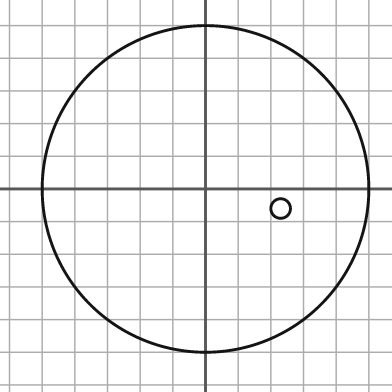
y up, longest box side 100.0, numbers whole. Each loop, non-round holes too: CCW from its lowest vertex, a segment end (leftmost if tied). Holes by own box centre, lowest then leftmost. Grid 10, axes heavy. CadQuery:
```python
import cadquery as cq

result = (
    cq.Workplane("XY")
    .moveTo(0.0, 0.0)
    .circle(50.0)
    .moveTo(23.0, -6.0)
    .circle(3.0)
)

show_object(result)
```